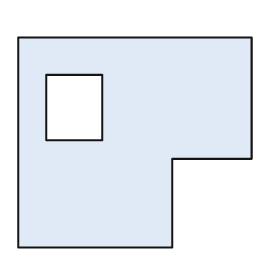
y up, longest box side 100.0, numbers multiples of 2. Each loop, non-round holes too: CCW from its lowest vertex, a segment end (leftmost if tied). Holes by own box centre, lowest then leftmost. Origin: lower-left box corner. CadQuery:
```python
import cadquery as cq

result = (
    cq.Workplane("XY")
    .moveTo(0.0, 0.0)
    .lineTo(66.0, 0.0)
    .lineTo(66.0, 38.0)
    .lineTo(100.0, 38.0)
    .lineTo(100.0, 90.0)
    .lineTo(0.0, 90.0)
    .close()
    .moveTo(12.0, 46.0)
    .lineTo(36.0, 46.0)
    .lineTo(36.0, 74.0)
    .lineTo(12.0, 74.0)
    .close()
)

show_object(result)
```